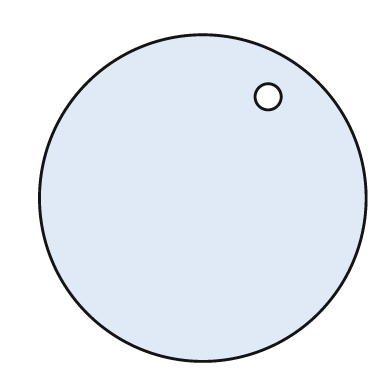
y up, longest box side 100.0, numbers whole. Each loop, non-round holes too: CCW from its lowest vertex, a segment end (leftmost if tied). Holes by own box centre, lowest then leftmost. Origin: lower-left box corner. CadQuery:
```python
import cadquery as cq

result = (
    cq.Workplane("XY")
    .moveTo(50.0, 50.0)
    .circle(50.0)
    .moveTo(70.0, 81.0)
    .circle(4.0)
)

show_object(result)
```